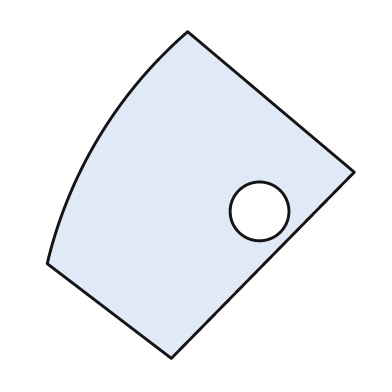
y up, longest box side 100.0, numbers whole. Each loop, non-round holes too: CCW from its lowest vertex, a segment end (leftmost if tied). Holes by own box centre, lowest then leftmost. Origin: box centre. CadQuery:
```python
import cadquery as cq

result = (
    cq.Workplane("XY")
    .moveTo(-9.0, -50.0)
    .lineTo(47.0, 7.0)
    .lineTo(-4.0, 50.0)
    .threePointArc((-31.0, 18.0), (-47.0, -21.0))
    .close()
    .moveTo(18.0, -5.0)
    .circle(9.0)
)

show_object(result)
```